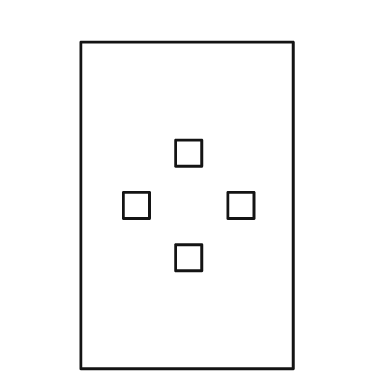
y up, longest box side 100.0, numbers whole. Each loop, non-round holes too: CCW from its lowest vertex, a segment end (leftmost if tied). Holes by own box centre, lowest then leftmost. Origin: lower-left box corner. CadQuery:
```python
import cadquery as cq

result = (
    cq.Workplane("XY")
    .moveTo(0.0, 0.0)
    .lineTo(65.0, 0.0)
    .lineTo(65.0, 100.0)
    .lineTo(0.0, 100.0)
    .close()
    .moveTo(29.0, 30.0)
    .lineTo(37.0, 30.0)
    .lineTo(37.0, 38.0)
    .lineTo(29.0, 38.0)
    .close()
    .moveTo(13.0, 46.0)
    .lineTo(21.0, 46.0)
    .lineTo(21.0, 54.0)
    .lineTo(13.0, 54.0)
    .close()
    .moveTo(45.0, 46.0)
    .lineTo(53.0, 46.0)
    .lineTo(53.0, 54.0)
    .lineTo(45.0, 54.0)
    .close()
    .moveTo(29.0, 62.0)
    .lineTo(37.0, 62.0)
    .lineTo(37.0, 70.0)
    .lineTo(29.0, 70.0)
    .close()
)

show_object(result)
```